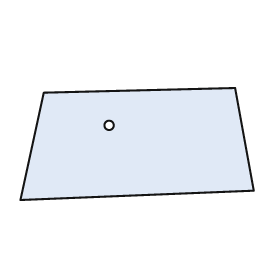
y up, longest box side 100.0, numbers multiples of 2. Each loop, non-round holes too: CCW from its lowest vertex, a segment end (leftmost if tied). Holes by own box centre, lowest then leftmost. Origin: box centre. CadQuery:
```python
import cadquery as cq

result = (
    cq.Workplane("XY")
    .moveTo(-50.0, -24.0)
    .lineTo(50.0, -20.0)
    .lineTo(42.0, 24.0)
    .lineTo(-40.0, 22.0)
    .close()
    .moveTo(-12.0, 8.0)
    .circle(2.0)
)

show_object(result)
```